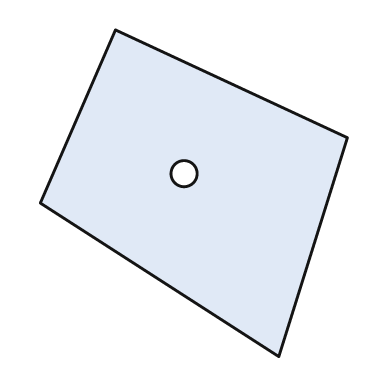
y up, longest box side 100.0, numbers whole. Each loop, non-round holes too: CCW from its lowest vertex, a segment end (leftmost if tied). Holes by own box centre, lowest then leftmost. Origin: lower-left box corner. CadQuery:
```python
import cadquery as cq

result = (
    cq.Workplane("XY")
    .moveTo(73.0, 0.0)
    .lineTo(94.0, 67.0)
    .lineTo(23.0, 100.0)
    .lineTo(0.0, 47.0)
    .close()
    .moveTo(44.0, 56.0)
    .circle(4.0)
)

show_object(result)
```